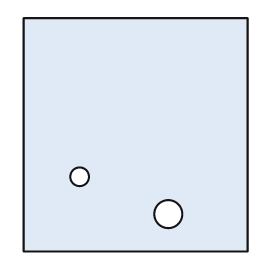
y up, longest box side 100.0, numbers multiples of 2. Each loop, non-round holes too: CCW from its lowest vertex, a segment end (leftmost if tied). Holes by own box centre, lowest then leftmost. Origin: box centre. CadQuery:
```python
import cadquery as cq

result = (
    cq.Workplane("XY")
    .moveTo(-48.0, -50.0)
    .lineTo(48.0, -50.0)
    .lineTo(48.0, 50.0)
    .lineTo(-48.0, 50.0)
    .close()
    .moveTo(14.0, -34.0)
    .circle(6.0)
    .moveTo(-24.0, -18.0)
    .circle(4.0)
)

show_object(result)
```